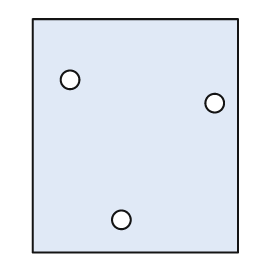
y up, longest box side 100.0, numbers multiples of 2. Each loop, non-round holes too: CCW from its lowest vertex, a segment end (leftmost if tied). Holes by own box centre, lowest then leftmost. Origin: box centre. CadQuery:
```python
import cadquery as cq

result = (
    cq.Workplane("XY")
    .moveTo(-44.0, -50.0)
    .lineTo(44.0, -50.0)
    .lineTo(44.0, 50.0)
    .lineTo(-44.0, 50.0)
    .close()
    .moveTo(-6.0, -36.0)
    .circle(4.0)
    .moveTo(34.0, 14.0)
    .circle(4.0)
    .moveTo(-28.0, 24.0)
    .circle(4.0)
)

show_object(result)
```